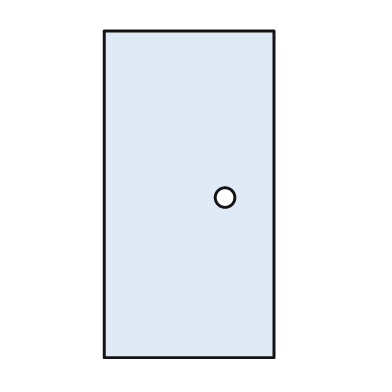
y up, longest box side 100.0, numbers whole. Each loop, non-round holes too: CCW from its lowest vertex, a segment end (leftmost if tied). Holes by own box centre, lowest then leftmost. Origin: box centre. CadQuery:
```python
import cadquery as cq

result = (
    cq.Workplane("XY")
    .moveTo(-26.0, -50.0)
    .lineTo(26.0, -50.0)
    .lineTo(26.0, 50.0)
    .lineTo(-26.0, 50.0)
    .close()
    .moveTo(11.0, -1.0)
    .circle(3.0)
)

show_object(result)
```